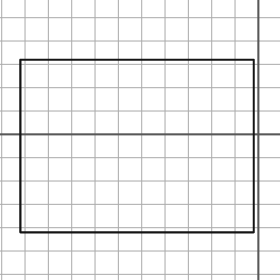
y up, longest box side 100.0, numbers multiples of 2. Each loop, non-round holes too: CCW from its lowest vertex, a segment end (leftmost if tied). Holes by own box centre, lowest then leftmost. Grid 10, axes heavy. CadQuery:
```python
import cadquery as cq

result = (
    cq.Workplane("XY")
    .moveTo(-102.0, -42.0)
    .lineTo(-2.0, -42.0)
    .lineTo(-2.0, 32.0)
    .lineTo(-102.0, 32.0)
    .close()
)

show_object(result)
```